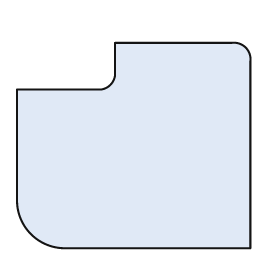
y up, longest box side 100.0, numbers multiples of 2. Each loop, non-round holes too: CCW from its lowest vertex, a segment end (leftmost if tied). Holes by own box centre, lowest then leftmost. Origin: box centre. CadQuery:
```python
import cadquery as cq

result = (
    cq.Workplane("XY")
    .moveTo(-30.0, -44.0)
    .lineTo(50.0, -44.0)
    .lineTo(50.0, 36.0)
    .threePointArc((48.0, 42.0), (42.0, 44.0))
    .lineTo(-8.0, 44.0)
    .lineTo(-8.0, 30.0)
    .threePointArc((-10.0, 26.0), (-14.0, 24.0))
    .lineTo(-50.0, 24.0)
    .lineTo(-50.0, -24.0)
    .threePointArc((-44.0, -38.0), (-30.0, -44.0))
    .close()
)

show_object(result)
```